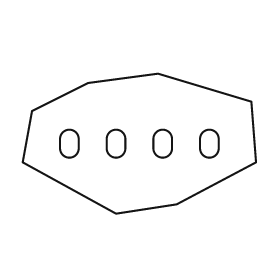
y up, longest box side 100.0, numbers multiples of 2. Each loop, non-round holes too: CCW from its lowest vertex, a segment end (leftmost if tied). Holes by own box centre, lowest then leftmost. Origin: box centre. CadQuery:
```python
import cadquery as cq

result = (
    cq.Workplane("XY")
    .moveTo(-10.0, -30.0)
    .lineTo(16.0, -26.0)
    .lineTo(50.0, -8.0)
    .lineTo(48.0, 18.0)
    .lineTo(8.0, 30.0)
    .lineTo(-22.0, 26.0)
    .lineTo(-46.0, 14.0)
    .lineTo(-50.0, -8.0)
    .close()
    .moveTo(-34.0, -2.0)
    .threePointArc((-30.0, -6.0), (-26.0, -2.0))
    .lineTo(-26.0, 2.0)
    .threePointArc((-30.0, 6.0), (-34.0, 2.0))
    .close()
    .moveTo(-14.0, -2.0)
    .threePointArc((-10.0, -6.0), (-6.0, -2.0))
    .lineTo(-6.0, 2.0)
    .threePointArc((-10.0, 6.0), (-14.0, 2.0))
    .close()
    .moveTo(6.0, -2.0)
    .threePointArc((10.0, -6.0), (14.0, -2.0))
    .lineTo(14.0, 2.0)
    .threePointArc((10.0, 6.0), (6.0, 2.0))
    .close()
    .moveTo(26.0, -2.0)
    .threePointArc((30.0, -6.0), (34.0, -2.0))
    .lineTo(34.0, 2.0)
    .threePointArc((30.0, 6.0), (26.0, 2.0))
    .close()
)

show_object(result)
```